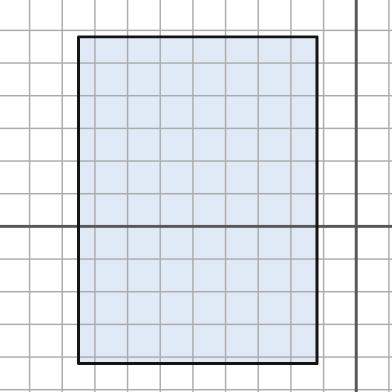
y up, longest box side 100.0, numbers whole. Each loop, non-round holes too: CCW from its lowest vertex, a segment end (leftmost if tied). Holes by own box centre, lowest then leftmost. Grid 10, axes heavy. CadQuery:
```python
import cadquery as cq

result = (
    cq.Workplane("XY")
    .moveTo(-85.0, -42.0)
    .lineTo(-12.0, -42.0)
    .lineTo(-12.0, 58.0)
    .lineTo(-85.0, 58.0)
    .close()
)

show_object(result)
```